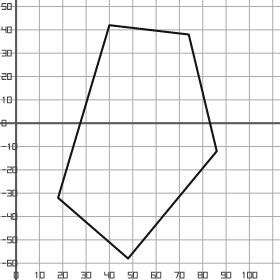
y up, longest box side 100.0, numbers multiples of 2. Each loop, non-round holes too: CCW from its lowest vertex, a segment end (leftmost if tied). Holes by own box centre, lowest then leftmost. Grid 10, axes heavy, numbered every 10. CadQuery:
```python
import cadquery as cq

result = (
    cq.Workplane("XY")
    .moveTo(48.0, -58.0)
    .lineTo(86.0, -12.0)
    .lineTo(74.0, 38.0)
    .lineTo(40.0, 42.0)
    .lineTo(18.0, -32.0)
    .close()
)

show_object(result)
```